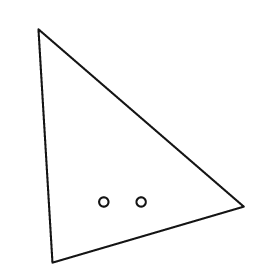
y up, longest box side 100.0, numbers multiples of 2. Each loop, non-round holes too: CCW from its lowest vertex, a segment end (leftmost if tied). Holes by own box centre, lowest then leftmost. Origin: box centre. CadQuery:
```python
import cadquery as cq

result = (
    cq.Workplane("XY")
    .moveTo(-38.0, -50.0)
    .lineTo(44.0, -26.0)
    .lineTo(-44.0, 50.0)
    .close()
    .moveTo(-16.0, -24.0)
    .circle(2.0)
    .moveTo(0.0, -24.0)
    .circle(2.0)
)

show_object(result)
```